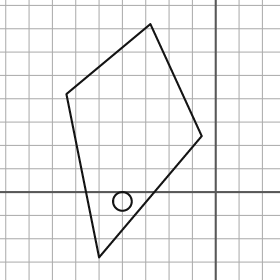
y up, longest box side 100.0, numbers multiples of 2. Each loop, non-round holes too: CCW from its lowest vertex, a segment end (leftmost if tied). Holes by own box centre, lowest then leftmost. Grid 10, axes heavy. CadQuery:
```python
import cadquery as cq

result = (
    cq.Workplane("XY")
    .moveTo(-50.0, -28.0)
    .lineTo(-6.0, 24.0)
    .lineTo(-28.0, 72.0)
    .lineTo(-64.0, 42.0)
    .close()
    .moveTo(-40.0, -4.0)
    .circle(4.0)
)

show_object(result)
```